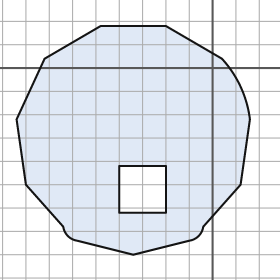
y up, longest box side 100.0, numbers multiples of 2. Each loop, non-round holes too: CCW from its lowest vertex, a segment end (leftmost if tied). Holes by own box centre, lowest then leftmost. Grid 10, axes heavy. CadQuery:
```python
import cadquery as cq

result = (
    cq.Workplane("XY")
    .moveTo(-34.0, -80.0)
    .lineTo(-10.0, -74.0)
    .threePointArc((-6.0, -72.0), (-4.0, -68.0))
    .lineTo(12.0, -50.0)
    .lineTo(16.0, -22.0)
    .threePointArc((12.0, -8.0), (4.0, 4.0))
    .lineTo(-20.0, 18.0)
    .lineTo(-48.0, 18.0)
    .lineTo(-72.0, 4.0)
    .lineTo(-84.0, -22.0)
    .lineTo(-80.0, -50.0)
    .lineTo(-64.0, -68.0)
    .threePointArc((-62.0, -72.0), (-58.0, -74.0))
    .close()
    .moveTo(-40.0, -62.0)
    .lineTo(-20.0, -62.0)
    .lineTo(-20.0, -42.0)
    .lineTo(-40.0, -42.0)
    .close()
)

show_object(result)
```